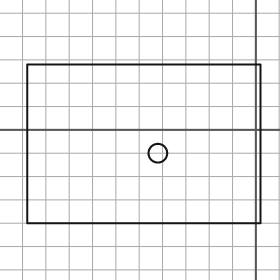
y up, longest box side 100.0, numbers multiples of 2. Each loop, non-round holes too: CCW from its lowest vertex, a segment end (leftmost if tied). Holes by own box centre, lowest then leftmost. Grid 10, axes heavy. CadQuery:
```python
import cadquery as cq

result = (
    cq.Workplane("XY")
    .moveTo(-98.0, -40.0)
    .lineTo(2.0, -40.0)
    .lineTo(2.0, 28.0)
    .lineTo(-98.0, 28.0)
    .close()
    .moveTo(-42.0, -10.0)
    .circle(4.0)
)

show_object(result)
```